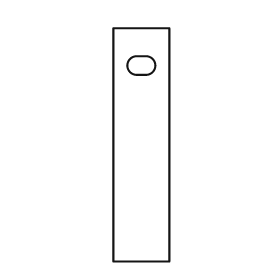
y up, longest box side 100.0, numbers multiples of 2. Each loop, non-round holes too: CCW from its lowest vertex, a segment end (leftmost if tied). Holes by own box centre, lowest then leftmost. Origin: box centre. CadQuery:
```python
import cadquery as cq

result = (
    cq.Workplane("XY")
    .moveTo(-12.0, -50.0)
    .lineTo(12.0, -50.0)
    .lineTo(12.0, 50.0)
    .lineTo(-12.0, 50.0)
    .close()
    .moveTo(-2.0, 30.0)
    .lineTo(2.0, 30.0)
    .threePointArc((6.0, 34.0), (2.0, 38.0))
    .lineTo(-2.0, 38.0)
    .threePointArc((-6.0, 34.0), (-2.0, 30.0))
    .close()
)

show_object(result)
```